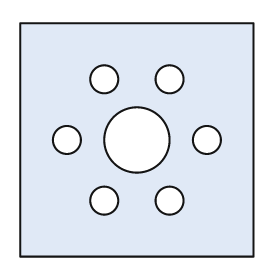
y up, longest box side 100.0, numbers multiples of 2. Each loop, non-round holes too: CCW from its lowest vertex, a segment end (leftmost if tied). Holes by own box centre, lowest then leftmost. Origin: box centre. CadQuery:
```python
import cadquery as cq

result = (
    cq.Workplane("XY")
    .moveTo(-50.0, -50.0)
    .lineTo(50.0, -50.0)
    .lineTo(50.0, 50.0)
    .lineTo(-50.0, 50.0)
    .close()
    .moveTo(-14.0, -26.0)
    .circle(6.0)
    .moveTo(14.0, -26.0)
    .circle(6.0)
    .moveTo(-30.0, 0.0)
    .circle(6.0)
    .moveTo(0.0, 0.0)
    .circle(14.0)
    .moveTo(30.0, 0.0)
    .circle(6.0)
    .moveTo(-14.0, 26.0)
    .circle(6.0)
    .moveTo(14.0, 26.0)
    .circle(6.0)
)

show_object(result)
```